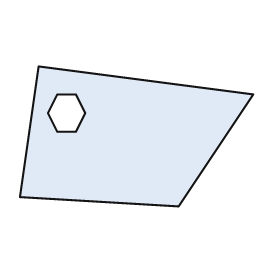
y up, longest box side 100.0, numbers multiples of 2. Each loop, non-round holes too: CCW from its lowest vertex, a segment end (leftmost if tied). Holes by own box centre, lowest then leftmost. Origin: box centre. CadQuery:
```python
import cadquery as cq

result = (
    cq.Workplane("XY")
    .moveTo(18.0, -30.0)
    .lineTo(50.0, 18.0)
    .lineTo(-42.0, 30.0)
    .lineTo(-50.0, -26.0)
    .close()
    .moveTo(-34.0, 2.0)
    .lineTo(-26.0, 2.0)
    .lineTo(-22.0, 10.0)
    .lineTo(-26.0, 18.0)
    .lineTo(-34.0, 18.0)
    .lineTo(-38.0, 10.0)
    .close()
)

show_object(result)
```